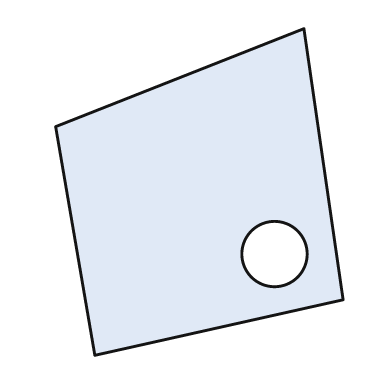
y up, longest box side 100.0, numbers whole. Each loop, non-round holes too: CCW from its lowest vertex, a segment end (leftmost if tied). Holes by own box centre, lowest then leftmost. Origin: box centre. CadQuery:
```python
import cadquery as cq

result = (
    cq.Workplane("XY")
    .moveTo(-32.0, -50.0)
    .lineTo(44.0, -33.0)
    .lineTo(32.0, 50.0)
    .lineTo(-44.0, 20.0)
    .close()
    .moveTo(23.0, -19.0)
    .circle(10.0)
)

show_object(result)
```